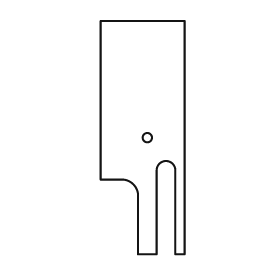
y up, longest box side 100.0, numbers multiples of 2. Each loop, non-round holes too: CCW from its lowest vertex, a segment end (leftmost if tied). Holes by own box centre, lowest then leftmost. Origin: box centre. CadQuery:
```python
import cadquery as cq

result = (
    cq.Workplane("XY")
    .moveTo(-2.0, -50.0)
    .lineTo(6.0, -50.0)
    .lineTo(6.0, -14.0)
    .threePointArc((10.0, -10.0), (14.0, -14.0))
    .lineTo(14.0, -50.0)
    .lineTo(18.0, -50.0)
    .lineTo(18.0, 50.0)
    .lineTo(-18.0, 50.0)
    .lineTo(-18.0, -18.0)
    .lineTo(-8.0, -18.0)
    .threePointArc((-4.0, -20.0), (-2.0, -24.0))
    .close()
    .moveTo(2.0, 0.0)
    .circle(2.0)
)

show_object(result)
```